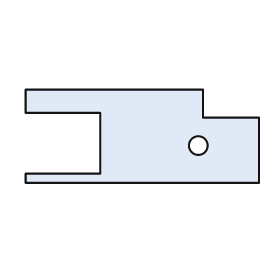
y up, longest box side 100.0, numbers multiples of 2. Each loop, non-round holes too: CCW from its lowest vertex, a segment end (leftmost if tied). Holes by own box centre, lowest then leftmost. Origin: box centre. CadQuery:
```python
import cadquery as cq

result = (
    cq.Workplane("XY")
    .moveTo(-50.0, -20.0)
    .lineTo(50.0, -20.0)
    .lineTo(50.0, 8.0)
    .lineTo(26.0, 8.0)
    .lineTo(26.0, 20.0)
    .lineTo(-50.0, 20.0)
    .lineTo(-50.0, 10.0)
    .lineTo(-18.0, 10.0)
    .lineTo(-18.0, -16.0)
    .lineTo(-50.0, -16.0)
    .close()
    .moveTo(24.0, -4.0)
    .circle(4.0)
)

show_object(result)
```